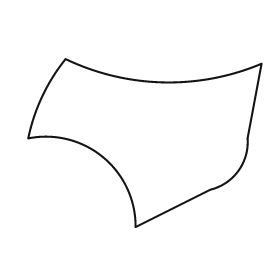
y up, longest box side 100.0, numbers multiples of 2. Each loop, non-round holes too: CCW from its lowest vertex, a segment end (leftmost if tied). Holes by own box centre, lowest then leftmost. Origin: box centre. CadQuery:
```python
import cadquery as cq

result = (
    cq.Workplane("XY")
    .moveTo(-4.0, -36.0)
    .lineTo(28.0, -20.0)
    .threePointArc((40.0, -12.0), (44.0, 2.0))
    .lineTo(50.0, 34.0)
    .threePointArc((8.0, 26.0), (-34.0, 36.0))
    .threePointArc((-44.0, 20.0), (-50.0, 2.0))
    .threePointArc((-18.0, -6.0), (-4.0, -36.0))
    .close()
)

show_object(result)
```